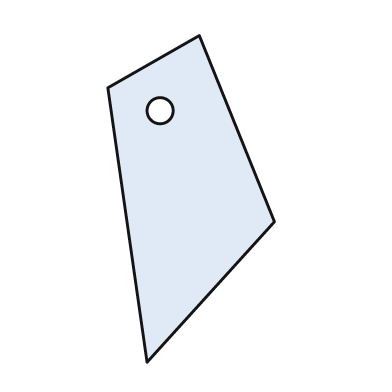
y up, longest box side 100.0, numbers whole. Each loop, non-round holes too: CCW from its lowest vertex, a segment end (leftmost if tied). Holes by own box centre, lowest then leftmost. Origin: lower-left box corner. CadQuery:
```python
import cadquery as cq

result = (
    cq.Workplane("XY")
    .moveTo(12.0, 0.0)
    .lineTo(51.0, 43.0)
    .lineTo(28.0, 100.0)
    .lineTo(0.0, 84.0)
    .close()
    .moveTo(16.0, 77.0)
    .circle(4.0)
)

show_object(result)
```